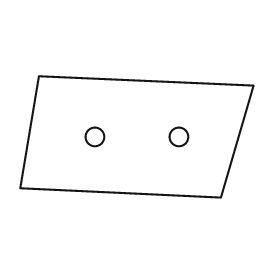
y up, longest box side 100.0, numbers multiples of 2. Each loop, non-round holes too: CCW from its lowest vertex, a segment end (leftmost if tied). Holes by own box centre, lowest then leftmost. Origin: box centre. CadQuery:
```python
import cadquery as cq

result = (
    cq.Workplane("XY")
    .moveTo(36.0, -26.0)
    .lineTo(50.0, 22.0)
    .lineTo(-42.0, 26.0)
    .lineTo(-50.0, -22.0)
    .close()
    .moveTo(-18.0, 0.0)
    .circle(4.0)
    .moveTo(18.0, 0.0)
    .circle(4.0)
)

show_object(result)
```